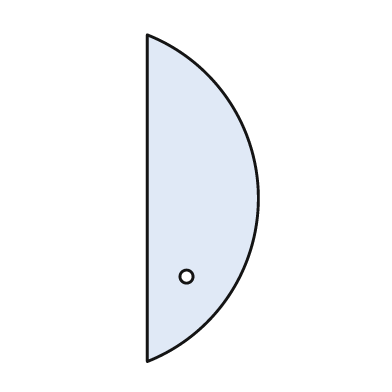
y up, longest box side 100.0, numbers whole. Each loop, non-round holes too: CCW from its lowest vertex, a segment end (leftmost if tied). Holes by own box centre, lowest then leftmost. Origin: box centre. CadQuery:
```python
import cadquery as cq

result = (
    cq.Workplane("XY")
    .moveTo(-17.0, -50.0)
    .threePointArc((17.0, 0.0), (-17.0, 50.0))
    .close()
    .moveTo(-5.0, -24.0)
    .circle(2.0)
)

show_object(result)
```